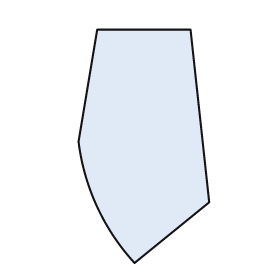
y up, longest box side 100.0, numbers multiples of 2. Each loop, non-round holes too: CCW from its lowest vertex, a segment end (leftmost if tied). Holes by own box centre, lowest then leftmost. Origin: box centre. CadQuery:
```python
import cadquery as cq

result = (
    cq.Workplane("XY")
    .moveTo(-4.0, -50.0)
    .lineTo(28.0, -24.0)
    .lineTo(20.0, 50.0)
    .lineTo(-20.0, 50.0)
    .lineTo(-28.0, 2.0)
    .threePointArc((-20.0, -26.0), (-4.0, -50.0))
    .close()
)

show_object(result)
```